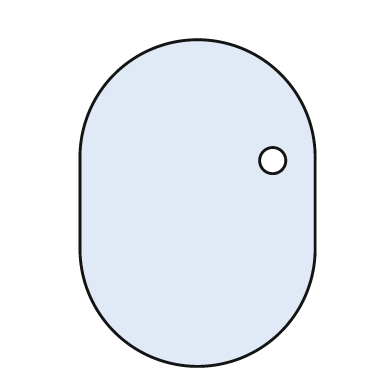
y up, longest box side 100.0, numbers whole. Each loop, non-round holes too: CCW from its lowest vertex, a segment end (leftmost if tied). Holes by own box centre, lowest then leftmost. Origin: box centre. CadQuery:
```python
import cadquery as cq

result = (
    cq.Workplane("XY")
    .moveTo(-36.0, -14.0)
    .threePointArc((0.0, -50.0), (36.0, -14.0))
    .lineTo(36.0, 14.0)
    .threePointArc((0.0, 50.0), (-36.0, 14.0))
    .close()
    .moveTo(23.0, 13.0)
    .circle(4.0)
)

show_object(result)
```